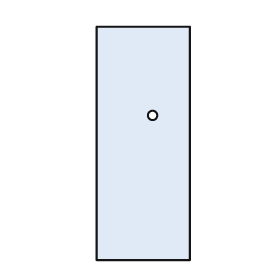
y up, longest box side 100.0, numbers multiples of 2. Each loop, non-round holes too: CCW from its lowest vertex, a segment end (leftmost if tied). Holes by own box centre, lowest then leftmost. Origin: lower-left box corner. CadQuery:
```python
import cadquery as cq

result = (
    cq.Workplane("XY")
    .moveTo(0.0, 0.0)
    .lineTo(40.0, 0.0)
    .lineTo(40.0, 100.0)
    .lineTo(0.0, 100.0)
    .close()
    .moveTo(24.0, 62.0)
    .circle(2.0)
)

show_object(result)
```